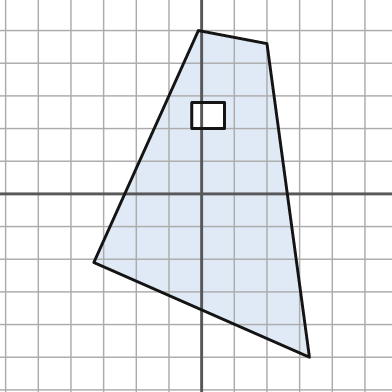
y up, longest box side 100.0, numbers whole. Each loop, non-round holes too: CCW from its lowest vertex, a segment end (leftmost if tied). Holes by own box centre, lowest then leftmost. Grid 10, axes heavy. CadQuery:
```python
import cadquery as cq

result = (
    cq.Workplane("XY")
    .moveTo(33.0, -50.0)
    .lineTo(20.0, 46.0)
    .lineTo(-1.0, 50.0)
    .lineTo(-33.0, -21.0)
    .close()
    .moveTo(-3.0, 20.0)
    .lineTo(7.0, 20.0)
    .lineTo(7.0, 28.0)
    .lineTo(-3.0, 28.0)
    .close()
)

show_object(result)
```